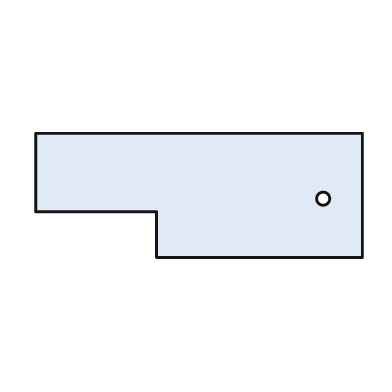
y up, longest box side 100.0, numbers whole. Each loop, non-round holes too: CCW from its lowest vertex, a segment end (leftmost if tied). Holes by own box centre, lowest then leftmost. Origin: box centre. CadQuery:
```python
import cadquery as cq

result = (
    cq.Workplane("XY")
    .moveTo(-13.0, -19.0)
    .lineTo(50.0, -19.0)
    .lineTo(50.0, 19.0)
    .lineTo(-50.0, 19.0)
    .lineTo(-50.0, -5.0)
    .lineTo(-13.0, -5.0)
    .close()
    .moveTo(38.0, -1.0)
    .circle(2.0)
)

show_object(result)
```